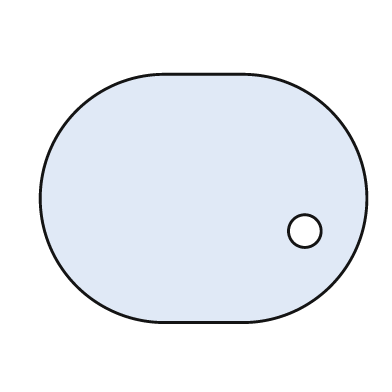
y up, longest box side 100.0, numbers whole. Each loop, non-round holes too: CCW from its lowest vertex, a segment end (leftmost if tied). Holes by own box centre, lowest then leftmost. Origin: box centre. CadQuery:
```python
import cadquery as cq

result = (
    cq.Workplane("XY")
    .moveTo(-12.0, -38.0)
    .lineTo(12.0, -38.0)
    .threePointArc((50.0, 0.0), (12.0, 38.0))
    .lineTo(-12.0, 38.0)
    .threePointArc((-50.0, 0.0), (-12.0, -38.0))
    .close()
    .moveTo(31.0, -10.0)
    .circle(5.0)
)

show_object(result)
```